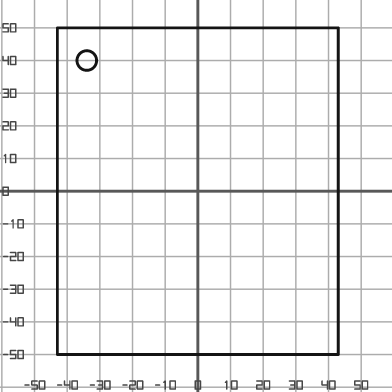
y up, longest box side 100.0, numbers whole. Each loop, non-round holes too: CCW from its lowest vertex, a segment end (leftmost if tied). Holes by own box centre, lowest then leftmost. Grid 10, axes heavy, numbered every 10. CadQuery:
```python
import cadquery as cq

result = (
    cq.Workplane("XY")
    .moveTo(-43.0, -50.0)
    .lineTo(43.0, -50.0)
    .lineTo(43.0, 50.0)
    .lineTo(-43.0, 50.0)
    .close()
    .moveTo(-34.0, 40.0)
    .circle(3.0)
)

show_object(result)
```